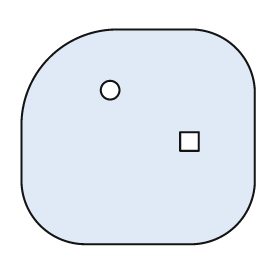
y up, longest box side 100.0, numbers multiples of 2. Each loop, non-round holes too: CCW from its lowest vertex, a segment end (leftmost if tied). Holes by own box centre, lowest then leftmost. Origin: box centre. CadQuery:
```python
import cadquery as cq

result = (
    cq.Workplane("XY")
    .moveTo(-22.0, -46.0)
    .lineTo(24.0, -46.0)
    .threePointArc((42.0, -38.0), (50.0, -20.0))
    .lineTo(50.0, 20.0)
    .threePointArc((42.0, 38.0), (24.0, 46.0))
    .lineTo(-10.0, 46.0)
    .threePointArc((-38.0, 34.0), (-50.0, 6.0))
    .lineTo(-50.0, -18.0)
    .threePointArc((-42.0, -38.0), (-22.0, -46.0))
    .close()
    .moveTo(18.0, -6.0)
    .lineTo(26.0, -6.0)
    .lineTo(26.0, 2.0)
    .lineTo(18.0, 2.0)
    .close()
    .moveTo(-12.0, 20.0)
    .circle(4.0)
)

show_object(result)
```